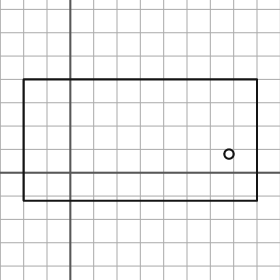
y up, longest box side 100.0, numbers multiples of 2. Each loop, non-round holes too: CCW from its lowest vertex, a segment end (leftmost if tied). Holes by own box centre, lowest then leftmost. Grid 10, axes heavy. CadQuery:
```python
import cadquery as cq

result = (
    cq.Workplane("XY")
    .moveTo(-20.0, -12.0)
    .lineTo(80.0, -12.0)
    .lineTo(80.0, 40.0)
    .lineTo(-20.0, 40.0)
    .close()
    .moveTo(68.0, 8.0)
    .circle(2.0)
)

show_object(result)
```